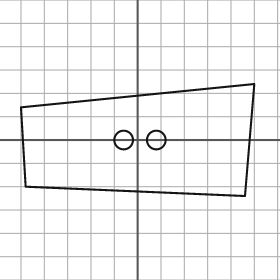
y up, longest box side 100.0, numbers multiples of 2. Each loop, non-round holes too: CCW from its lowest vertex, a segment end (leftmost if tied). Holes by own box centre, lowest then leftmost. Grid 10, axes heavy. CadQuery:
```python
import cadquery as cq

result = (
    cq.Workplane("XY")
    .moveTo(46.0, -24.0)
    .lineTo(50.0, 24.0)
    .lineTo(-50.0, 14.0)
    .lineTo(-48.0, -20.0)
    .close()
    .moveTo(-6.0, 0.0)
    .circle(4.0)
    .moveTo(8.0, 0.0)
    .circle(4.0)
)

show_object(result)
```